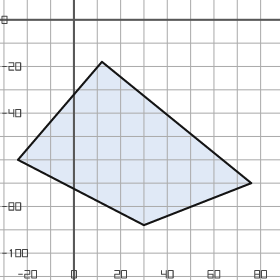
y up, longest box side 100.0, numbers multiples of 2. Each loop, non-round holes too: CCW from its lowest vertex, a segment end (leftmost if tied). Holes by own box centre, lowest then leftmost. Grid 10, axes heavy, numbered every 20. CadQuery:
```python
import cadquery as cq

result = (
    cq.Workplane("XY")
    .moveTo(30.0, -88.0)
    .lineTo(76.0, -70.0)
    .lineTo(12.0, -18.0)
    .lineTo(-24.0, -60.0)
    .close()
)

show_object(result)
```